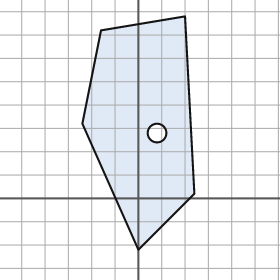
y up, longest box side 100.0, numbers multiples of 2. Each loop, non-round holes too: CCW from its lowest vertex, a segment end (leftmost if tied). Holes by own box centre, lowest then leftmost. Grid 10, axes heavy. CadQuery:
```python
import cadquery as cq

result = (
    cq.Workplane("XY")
    .moveTo(0.0, -22.0)
    .lineTo(24.0, 2.0)
    .lineTo(20.0, 78.0)
    .lineTo(-16.0, 72.0)
    .lineTo(-24.0, 32.0)
    .close()
    .moveTo(8.0, 28.0)
    .circle(4.0)
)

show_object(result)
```